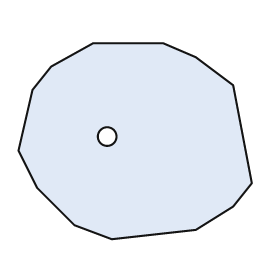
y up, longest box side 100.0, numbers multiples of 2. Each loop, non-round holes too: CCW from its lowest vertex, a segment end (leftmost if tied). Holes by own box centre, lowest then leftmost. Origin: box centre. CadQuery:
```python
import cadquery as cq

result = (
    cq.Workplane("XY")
    .moveTo(-10.0, -42.0)
    .lineTo(26.0, -38.0)
    .lineTo(42.0, -28.0)
    .lineTo(50.0, -18.0)
    .lineTo(42.0, 24.0)
    .lineTo(26.0, 36.0)
    .lineTo(12.0, 42.0)
    .lineTo(-18.0, 42.0)
    .lineTo(-36.0, 32.0)
    .lineTo(-44.0, 22.0)
    .lineTo(-50.0, -4.0)
    .lineTo(-42.0, -20.0)
    .lineTo(-26.0, -36.0)
    .close()
    .moveTo(-12.0, 2.0)
    .circle(4.0)
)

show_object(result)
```